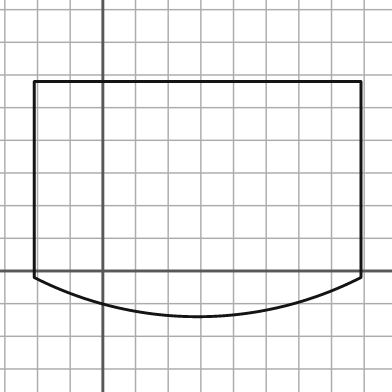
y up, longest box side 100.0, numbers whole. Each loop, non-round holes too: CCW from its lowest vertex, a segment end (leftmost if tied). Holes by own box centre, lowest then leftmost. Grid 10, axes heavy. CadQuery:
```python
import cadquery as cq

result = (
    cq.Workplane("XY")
    .moveTo(-21.0, -2.0)
    .threePointArc((29.0, -14.0), (79.0, -2.0))
    .lineTo(79.0, 58.0)
    .lineTo(-21.0, 58.0)
    .close()
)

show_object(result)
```